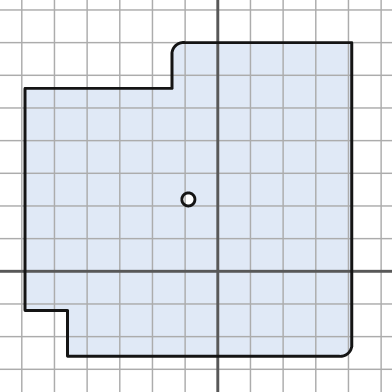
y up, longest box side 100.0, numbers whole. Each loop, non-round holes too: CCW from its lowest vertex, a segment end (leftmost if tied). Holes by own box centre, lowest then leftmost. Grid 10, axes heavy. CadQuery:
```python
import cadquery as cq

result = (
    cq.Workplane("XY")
    .moveTo(-46.0, -26.0)
    .lineTo(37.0, -26.0)
    .threePointArc((40.0, -25.0), (41.0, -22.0))
    .lineTo(41.0, 70.0)
    .lineTo(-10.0, 70.0)
    .threePointArc((-13.0, 69.0), (-14.0, 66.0))
    .lineTo(-14.0, 56.0)
    .lineTo(-59.0, 56.0)
    .lineTo(-59.0, -12.0)
    .lineTo(-46.0, -12.0)
    .close()
    .moveTo(-9.0, 22.0)
    .circle(2.0)
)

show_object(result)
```